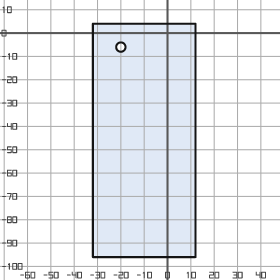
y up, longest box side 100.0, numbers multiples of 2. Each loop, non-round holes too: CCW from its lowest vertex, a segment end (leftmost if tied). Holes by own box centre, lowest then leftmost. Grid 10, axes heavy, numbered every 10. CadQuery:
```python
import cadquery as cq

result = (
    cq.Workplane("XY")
    .moveTo(-32.0, -96.0)
    .lineTo(12.0, -96.0)
    .lineTo(12.0, 4.0)
    .lineTo(-32.0, 4.0)
    .close()
    .moveTo(-20.0, -6.0)
    .circle(2.0)
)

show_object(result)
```